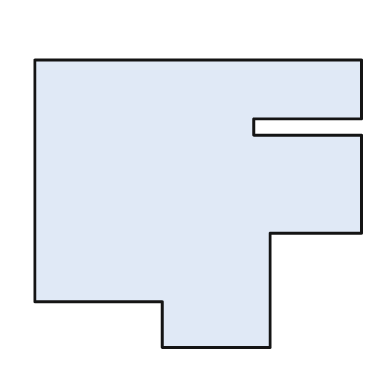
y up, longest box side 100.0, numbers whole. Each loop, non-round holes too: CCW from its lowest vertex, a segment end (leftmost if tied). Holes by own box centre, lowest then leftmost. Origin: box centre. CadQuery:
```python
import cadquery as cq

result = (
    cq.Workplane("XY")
    .moveTo(-11.0, -44.0)
    .lineTo(22.0, -44.0)
    .lineTo(22.0, -9.0)
    .lineTo(50.0, -9.0)
    .lineTo(50.0, 21.0)
    .lineTo(17.0, 21.0)
    .lineTo(17.0, 26.0)
    .lineTo(50.0, 26.0)
    .lineTo(50.0, 44.0)
    .lineTo(-50.0, 44.0)
    .lineTo(-50.0, -30.0)
    .lineTo(-11.0, -30.0)
    .close()
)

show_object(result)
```